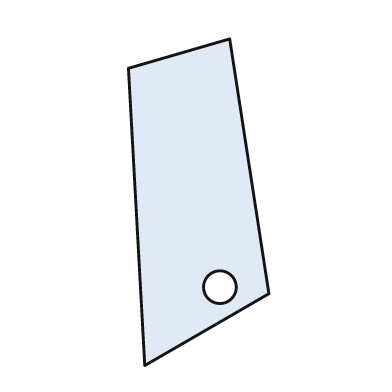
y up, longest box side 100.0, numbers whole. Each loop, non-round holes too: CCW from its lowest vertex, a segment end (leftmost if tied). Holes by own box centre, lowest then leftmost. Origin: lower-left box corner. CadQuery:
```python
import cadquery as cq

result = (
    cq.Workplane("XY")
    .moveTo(5.0, 0.0)
    .lineTo(43.0, 22.0)
    .lineTo(31.0, 100.0)
    .lineTo(0.0, 91.0)
    .close()
    .moveTo(28.0, 24.0)
    .circle(5.0)
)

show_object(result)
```